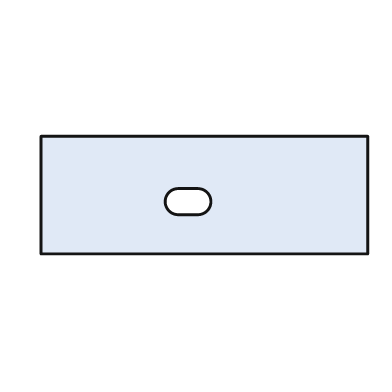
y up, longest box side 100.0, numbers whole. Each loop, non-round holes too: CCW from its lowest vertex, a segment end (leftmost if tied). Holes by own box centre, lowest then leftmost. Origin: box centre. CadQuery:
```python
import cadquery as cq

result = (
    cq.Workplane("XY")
    .moveTo(-50.0, -18.0)
    .lineTo(50.0, -18.0)
    .lineTo(50.0, 18.0)
    .lineTo(-50.0, 18.0)
    .close()
    .moveTo(-8.0, -6.0)
    .lineTo(-2.0, -6.0)
    .threePointArc((2.0, -2.0), (-2.0, 2.0))
    .lineTo(-8.0, 2.0)
    .threePointArc((-12.0, -2.0), (-8.0, -6.0))
    .close()
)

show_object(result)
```